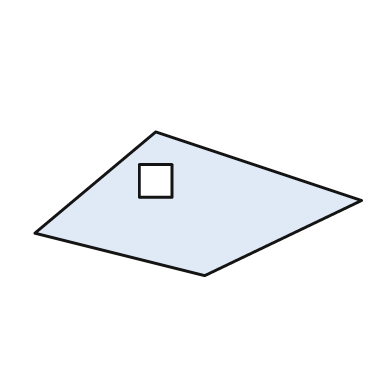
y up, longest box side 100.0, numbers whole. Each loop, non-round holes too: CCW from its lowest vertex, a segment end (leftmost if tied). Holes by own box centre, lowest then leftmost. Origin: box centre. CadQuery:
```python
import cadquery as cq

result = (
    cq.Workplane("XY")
    .moveTo(2.0, -22.0)
    .lineTo(50.0, 1.0)
    .lineTo(-13.0, 22.0)
    .lineTo(-50.0, -9.0)
    .close()
    .moveTo(-18.0, 2.0)
    .lineTo(-8.0, 2.0)
    .lineTo(-8.0, 12.0)
    .lineTo(-18.0, 12.0)
    .close()
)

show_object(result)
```